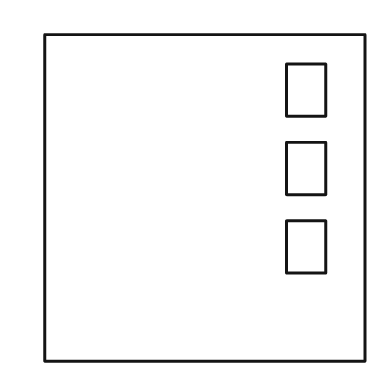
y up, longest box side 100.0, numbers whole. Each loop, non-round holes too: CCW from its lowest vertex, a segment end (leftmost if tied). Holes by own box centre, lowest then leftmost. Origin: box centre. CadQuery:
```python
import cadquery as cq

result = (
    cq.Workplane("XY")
    .moveTo(-49.0, -50.0)
    .lineTo(49.0, -50.0)
    .lineTo(49.0, 50.0)
    .lineTo(-49.0, 50.0)
    .close()
    .moveTo(25.0, -23.0)
    .lineTo(37.0, -23.0)
    .lineTo(37.0, -7.0)
    .lineTo(25.0, -7.0)
    .close()
    .moveTo(25.0, 1.0)
    .lineTo(37.0, 1.0)
    .lineTo(37.0, 17.0)
    .lineTo(25.0, 17.0)
    .close()
    .moveTo(25.0, 25.0)
    .lineTo(37.0, 25.0)
    .lineTo(37.0, 41.0)
    .lineTo(25.0, 41.0)
    .close()
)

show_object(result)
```